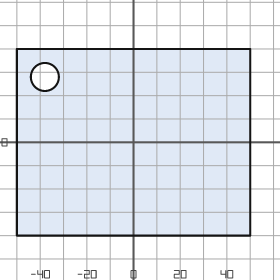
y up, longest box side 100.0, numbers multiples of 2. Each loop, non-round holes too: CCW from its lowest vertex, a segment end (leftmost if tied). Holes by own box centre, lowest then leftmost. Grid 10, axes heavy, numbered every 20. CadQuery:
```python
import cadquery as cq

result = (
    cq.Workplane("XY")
    .moveTo(-50.0, -40.0)
    .lineTo(50.0, -40.0)
    .lineTo(50.0, 40.0)
    .lineTo(-50.0, 40.0)
    .close()
    .moveTo(-38.0, 28.0)
    .circle(6.0)
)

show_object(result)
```